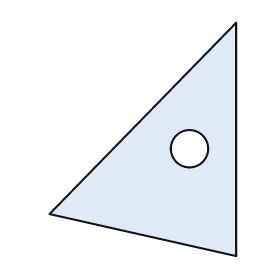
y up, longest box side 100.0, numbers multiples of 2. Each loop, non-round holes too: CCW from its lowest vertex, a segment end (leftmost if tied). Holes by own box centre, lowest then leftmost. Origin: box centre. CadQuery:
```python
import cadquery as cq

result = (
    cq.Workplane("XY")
    .moveTo(40.0, -50.0)
    .lineTo(40.0, 50.0)
    .lineTo(-40.0, -32.0)
    .close()
    .moveTo(20.0, -4.0)
    .circle(8.0)
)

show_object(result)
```